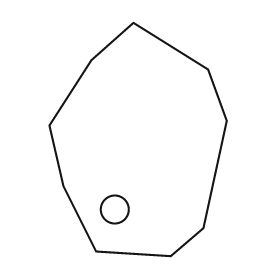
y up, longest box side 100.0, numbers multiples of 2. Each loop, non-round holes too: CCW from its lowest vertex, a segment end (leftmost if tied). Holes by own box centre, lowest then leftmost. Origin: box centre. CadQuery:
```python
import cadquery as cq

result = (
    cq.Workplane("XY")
    .moveTo(14.0, -50.0)
    .lineTo(28.0, -38.0)
    .lineTo(38.0, 8.0)
    .lineTo(30.0, 30.0)
    .lineTo(-2.0, 50.0)
    .lineTo(-20.0, 34.0)
    .lineTo(-38.0, 6.0)
    .lineTo(-32.0, -20.0)
    .lineTo(-18.0, -48.0)
    .close()
    .moveTo(-10.0, -30.0)
    .circle(6.0)
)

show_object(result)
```